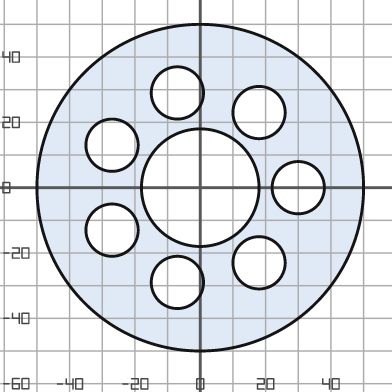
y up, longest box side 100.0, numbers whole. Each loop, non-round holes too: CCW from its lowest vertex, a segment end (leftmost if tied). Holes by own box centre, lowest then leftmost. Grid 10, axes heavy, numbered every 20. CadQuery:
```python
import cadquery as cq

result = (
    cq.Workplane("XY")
    .moveTo(0.0, 0.0)
    .circle(50.0)
    .moveTo(-7.0, -29.0)
    .circle(8.0)
    .moveTo(18.0, -23.0)
    .circle(8.0)
    .moveTo(-27.0, -13.0)
    .circle(8.0)
    .moveTo(0.0, 0.0)
    .circle(18.0)
    .moveTo(30.0, 0.0)
    .circle(8.0)
    .moveTo(-27.0, 13.0)
    .circle(8.0)
    .moveTo(18.0, 23.0)
    .circle(8.0)
    .moveTo(-7.0, 29.0)
    .circle(8.0)
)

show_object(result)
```